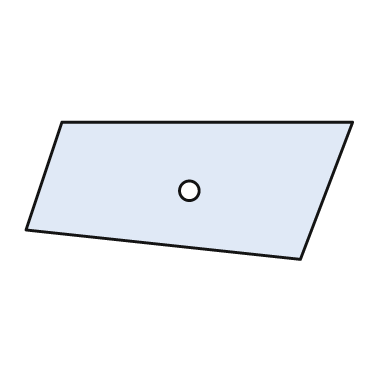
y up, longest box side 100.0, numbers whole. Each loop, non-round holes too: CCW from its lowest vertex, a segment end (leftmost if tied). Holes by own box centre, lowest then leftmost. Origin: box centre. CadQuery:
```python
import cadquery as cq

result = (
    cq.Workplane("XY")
    .moveTo(34.0, -21.0)
    .lineTo(50.0, 21.0)
    .lineTo(-39.0, 21.0)
    .lineTo(-50.0, -12.0)
    .close()
    .moveTo(0.0, 0.0)
    .circle(3.0)
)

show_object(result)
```